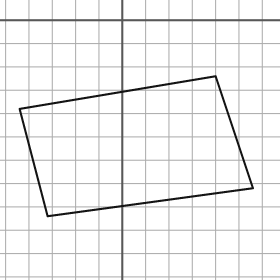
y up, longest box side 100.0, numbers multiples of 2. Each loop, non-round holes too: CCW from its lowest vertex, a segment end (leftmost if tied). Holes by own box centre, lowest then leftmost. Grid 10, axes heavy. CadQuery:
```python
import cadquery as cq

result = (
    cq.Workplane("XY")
    .moveTo(-32.0, -84.0)
    .lineTo(56.0, -72.0)
    .lineTo(40.0, -24.0)
    .lineTo(-44.0, -38.0)
    .close()
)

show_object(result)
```